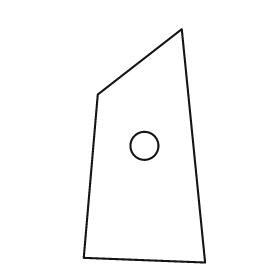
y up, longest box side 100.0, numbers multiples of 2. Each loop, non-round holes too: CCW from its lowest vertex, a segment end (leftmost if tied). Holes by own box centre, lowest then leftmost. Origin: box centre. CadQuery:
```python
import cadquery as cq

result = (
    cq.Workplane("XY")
    .moveTo(26.0, -50.0)
    .lineTo(16.0, 50.0)
    .lineTo(-20.0, 22.0)
    .lineTo(-26.0, -48.0)
    .close()
    .moveTo(0.0, 0.0)
    .circle(6.0)
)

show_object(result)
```